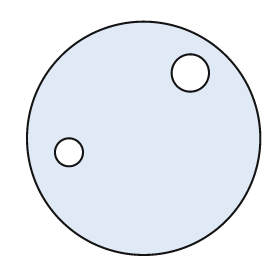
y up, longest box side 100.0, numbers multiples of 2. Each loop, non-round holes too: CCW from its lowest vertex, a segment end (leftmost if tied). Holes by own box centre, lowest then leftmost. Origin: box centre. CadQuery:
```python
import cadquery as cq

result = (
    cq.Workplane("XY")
    .moveTo(0.0, 0.0)
    .circle(50.0)
    .moveTo(-32.0, -6.0)
    .circle(6.0)
    .moveTo(20.0, 28.0)
    .circle(8.0)
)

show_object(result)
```